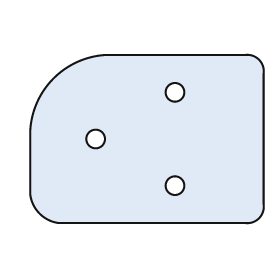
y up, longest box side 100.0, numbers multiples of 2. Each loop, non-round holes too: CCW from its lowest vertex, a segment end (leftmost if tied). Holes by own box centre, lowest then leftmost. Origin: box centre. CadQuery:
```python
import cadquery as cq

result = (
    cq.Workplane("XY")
    .moveTo(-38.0, -36.0)
    .lineTo(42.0, -36.0)
    .threePointArc((48.0, -34.0), (50.0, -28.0))
    .lineTo(50.0, 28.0)
    .threePointArc((48.0, 34.0), (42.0, 36.0))
    .lineTo(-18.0, 36.0)
    .threePointArc((-40.0, 26.0), (-50.0, 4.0))
    .lineTo(-50.0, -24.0)
    .threePointArc((-46.0, -32.0), (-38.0, -36.0))
    .close()
    .moveTo(12.0, -20.0)
    .circle(4.0)
    .moveTo(-22.0, 0.0)
    .circle(4.0)
    .moveTo(12.0, 20.0)
    .circle(4.0)
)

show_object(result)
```